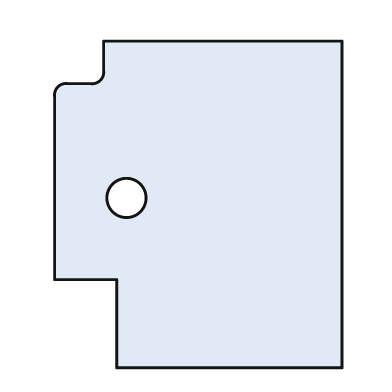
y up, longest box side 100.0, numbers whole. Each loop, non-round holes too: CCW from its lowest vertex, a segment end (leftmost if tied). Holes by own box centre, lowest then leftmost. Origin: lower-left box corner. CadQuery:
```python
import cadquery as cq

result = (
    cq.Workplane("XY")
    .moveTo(19.0, 0.0)
    .lineTo(88.0, 0.0)
    .lineTo(88.0, 100.0)
    .lineTo(15.0, 100.0)
    .lineTo(15.0, 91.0)
    .threePointArc((14.0, 88.0), (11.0, 87.0))
    .lineTo(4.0, 87.0)
    .threePointArc((1.0, 86.0), (0.0, 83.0))
    .lineTo(0.0, 27.0)
    .lineTo(19.0, 27.0)
    .close()
    .moveTo(22.0, 52.0)
    .circle(6.0)
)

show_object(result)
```